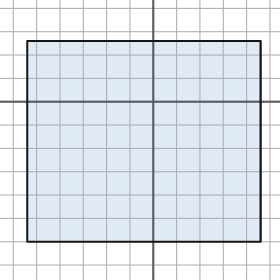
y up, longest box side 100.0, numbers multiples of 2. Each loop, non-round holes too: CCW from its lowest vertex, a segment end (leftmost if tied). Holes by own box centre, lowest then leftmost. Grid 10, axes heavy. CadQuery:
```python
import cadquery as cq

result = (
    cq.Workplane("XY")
    .moveTo(-54.0, -60.0)
    .lineTo(46.0, -60.0)
    .lineTo(46.0, 26.0)
    .lineTo(-54.0, 26.0)
    .close()
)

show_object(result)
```